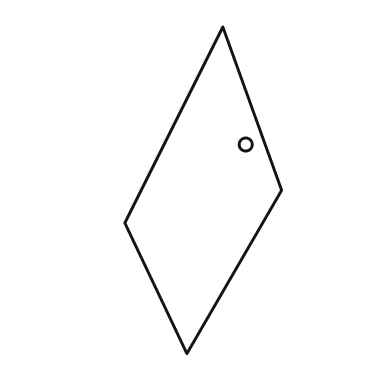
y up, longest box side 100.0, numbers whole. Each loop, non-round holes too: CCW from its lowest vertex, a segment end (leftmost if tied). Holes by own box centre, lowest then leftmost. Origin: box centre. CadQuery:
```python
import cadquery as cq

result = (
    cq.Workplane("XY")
    .moveTo(-5.0, -50.0)
    .lineTo(24.0, 0.0)
    .lineTo(6.0, 50.0)
    .lineTo(-24.0, -10.0)
    .close()
    .moveTo(13.0, 14.0)
    .circle(2.0)
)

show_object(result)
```